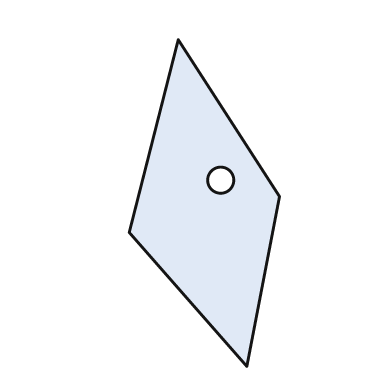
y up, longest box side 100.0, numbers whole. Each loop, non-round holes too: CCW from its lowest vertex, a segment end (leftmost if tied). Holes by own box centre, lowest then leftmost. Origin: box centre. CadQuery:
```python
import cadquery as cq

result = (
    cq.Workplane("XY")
    .moveTo(13.0, -50.0)
    .lineTo(23.0, 2.0)
    .lineTo(-8.0, 50.0)
    .lineTo(-23.0, -9.0)
    .close()
    .moveTo(5.0, 7.0)
    .circle(4.0)
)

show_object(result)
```